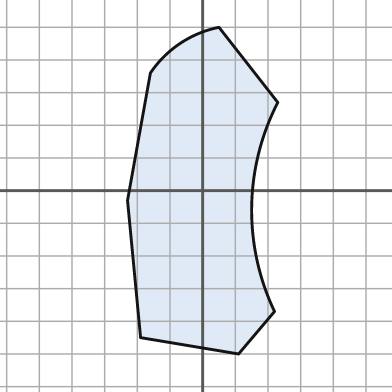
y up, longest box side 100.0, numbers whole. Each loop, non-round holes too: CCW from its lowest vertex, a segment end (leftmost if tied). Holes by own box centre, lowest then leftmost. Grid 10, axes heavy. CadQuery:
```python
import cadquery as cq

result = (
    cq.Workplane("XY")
    .moveTo(11.0, -50.0)
    .lineTo(22.0, -37.0)
    .threePointArc((15.0, -5.0), (23.0, 27.0))
    .lineTo(5.0, 50.0)
    .threePointArc((-7.0, 45.0), (-16.0, 36.0))
    .lineTo(-23.0, -3.0)
    .lineTo(-19.0, -45.0)
    .close()
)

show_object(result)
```